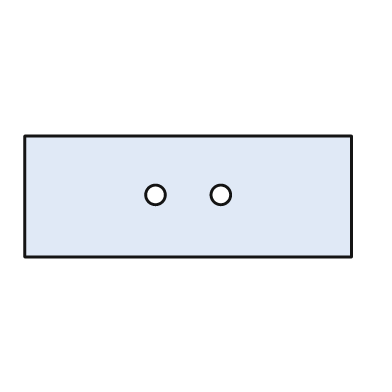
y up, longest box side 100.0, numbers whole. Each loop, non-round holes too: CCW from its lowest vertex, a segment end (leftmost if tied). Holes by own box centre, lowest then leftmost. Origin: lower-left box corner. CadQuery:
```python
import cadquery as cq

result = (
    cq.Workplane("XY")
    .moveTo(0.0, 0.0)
    .lineTo(100.0, 0.0)
    .lineTo(100.0, 37.0)
    .lineTo(0.0, 37.0)
    .close()
    .moveTo(40.0, 19.0)
    .circle(3.0)
    .moveTo(60.0, 19.0)
    .circle(3.0)
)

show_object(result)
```